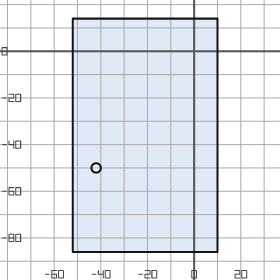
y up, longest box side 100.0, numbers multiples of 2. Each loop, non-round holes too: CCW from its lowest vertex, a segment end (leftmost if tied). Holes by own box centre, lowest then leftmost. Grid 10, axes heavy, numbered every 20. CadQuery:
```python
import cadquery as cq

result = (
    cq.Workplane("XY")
    .moveTo(-52.0, -86.0)
    .lineTo(10.0, -86.0)
    .lineTo(10.0, 14.0)
    .lineTo(-52.0, 14.0)
    .close()
    .moveTo(-42.0, -50.0)
    .circle(2.0)
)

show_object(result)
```